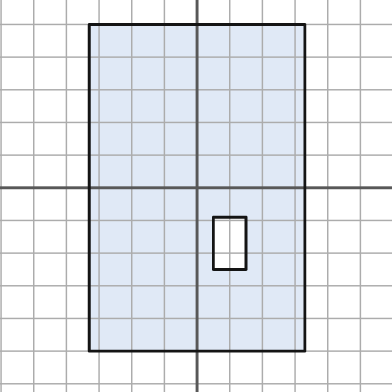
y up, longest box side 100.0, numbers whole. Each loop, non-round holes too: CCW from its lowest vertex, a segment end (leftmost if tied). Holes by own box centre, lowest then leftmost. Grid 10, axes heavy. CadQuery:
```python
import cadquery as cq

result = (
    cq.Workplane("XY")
    .moveTo(-33.0, -50.0)
    .lineTo(33.0, -50.0)
    .lineTo(33.0, 50.0)
    .lineTo(-33.0, 50.0)
    .close()
    .moveTo(5.0, -25.0)
    .lineTo(15.0, -25.0)
    .lineTo(15.0, -9.0)
    .lineTo(5.0, -9.0)
    .close()
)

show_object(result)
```